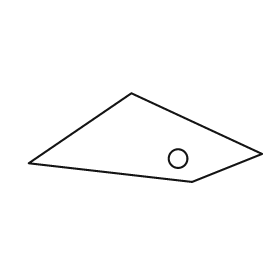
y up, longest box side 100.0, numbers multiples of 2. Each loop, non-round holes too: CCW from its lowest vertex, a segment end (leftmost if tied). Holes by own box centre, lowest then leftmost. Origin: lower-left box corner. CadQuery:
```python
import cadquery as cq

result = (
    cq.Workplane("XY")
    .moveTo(70.0, 0.0)
    .lineTo(100.0, 12.0)
    .lineTo(44.0, 38.0)
    .lineTo(0.0, 8.0)
    .close()
    .moveTo(64.0, 10.0)
    .circle(4.0)
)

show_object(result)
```